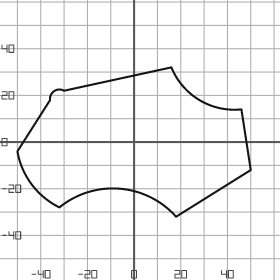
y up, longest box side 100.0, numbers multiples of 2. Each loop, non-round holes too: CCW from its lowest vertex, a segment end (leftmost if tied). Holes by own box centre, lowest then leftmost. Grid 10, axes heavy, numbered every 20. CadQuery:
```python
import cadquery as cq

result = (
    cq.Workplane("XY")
    .moveTo(18.0, -32.0)
    .lineTo(50.0, -12.0)
    .lineTo(46.0, 14.0)
    .threePointArc((28.0, 18.0), (16.0, 32.0))
    .lineTo(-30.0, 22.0)
    .threePointArc((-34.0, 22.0), (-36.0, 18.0))
    .lineTo(-50.0, -4.0)
    .threePointArc((-44.0, -18.0), (-32.0, -28.0))
    .threePointArc((-6.0, -20.0), (18.0, -32.0))
    .close()
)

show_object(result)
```